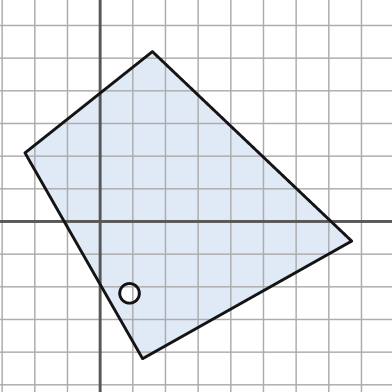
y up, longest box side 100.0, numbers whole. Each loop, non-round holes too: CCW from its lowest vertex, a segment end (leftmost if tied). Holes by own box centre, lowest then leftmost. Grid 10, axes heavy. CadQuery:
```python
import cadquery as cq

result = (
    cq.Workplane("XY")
    .moveTo(13.0, -42.0)
    .lineTo(77.0, -6.0)
    .lineTo(16.0, 52.0)
    .lineTo(-23.0, 21.0)
    .close()
    .moveTo(9.0, -22.0)
    .circle(3.0)
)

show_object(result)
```